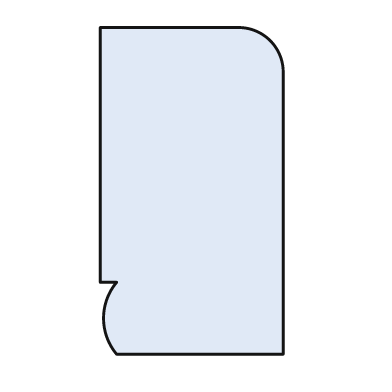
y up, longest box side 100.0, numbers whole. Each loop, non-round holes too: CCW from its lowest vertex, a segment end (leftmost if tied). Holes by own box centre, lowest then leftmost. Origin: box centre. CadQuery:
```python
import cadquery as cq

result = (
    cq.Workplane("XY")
    .moveTo(-23.0, -50.0)
    .lineTo(28.0, -50.0)
    .lineTo(28.0, 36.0)
    .threePointArc((24.0, 46.0), (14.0, 50.0))
    .lineTo(-28.0, 50.0)
    .lineTo(-28.0, -28.0)
    .lineTo(-23.0, -28.0)
    .threePointArc((-27.0, -39.0), (-23.0, -50.0))
    .close()
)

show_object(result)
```